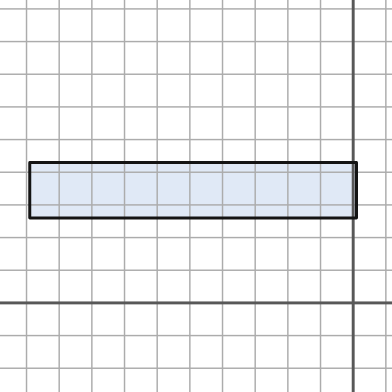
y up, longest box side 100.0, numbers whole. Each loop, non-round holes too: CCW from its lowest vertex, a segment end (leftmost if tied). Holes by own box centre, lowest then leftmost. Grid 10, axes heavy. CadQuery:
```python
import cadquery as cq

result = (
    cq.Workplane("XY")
    .moveTo(-99.0, 26.0)
    .lineTo(1.0, 26.0)
    .lineTo(1.0, 43.0)
    .lineTo(-99.0, 43.0)
    .close()
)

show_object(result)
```